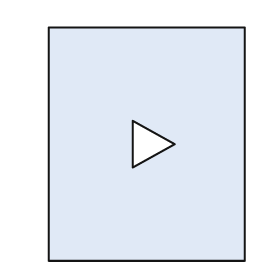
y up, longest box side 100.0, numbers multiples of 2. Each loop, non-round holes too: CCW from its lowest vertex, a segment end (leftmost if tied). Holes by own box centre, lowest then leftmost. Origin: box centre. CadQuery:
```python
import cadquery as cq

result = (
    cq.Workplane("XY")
    .moveTo(-42.0, -50.0)
    .lineTo(42.0, -50.0)
    .lineTo(42.0, 50.0)
    .lineTo(-42.0, 50.0)
    .close()
    .moveTo(-6.0, -10.0)
    .lineTo(12.0, 0.0)
    .lineTo(-6.0, 10.0)
    .close()
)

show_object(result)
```